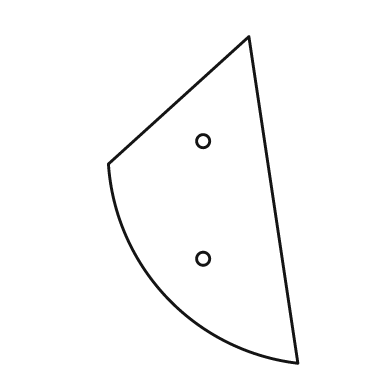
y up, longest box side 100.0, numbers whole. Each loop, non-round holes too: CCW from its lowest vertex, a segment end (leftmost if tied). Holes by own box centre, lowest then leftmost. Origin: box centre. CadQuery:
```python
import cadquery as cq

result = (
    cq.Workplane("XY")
    .moveTo(29.0, -50.0)
    .lineTo(14.0, 50.0)
    .lineTo(-29.0, 11.0)
    .threePointArc((-11.0, -30.0), (29.0, -50.0))
    .close()
    .moveTo(0.0, -18.0)
    .circle(2.0)
    .moveTo(0.0, 18.0)
    .circle(2.0)
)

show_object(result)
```